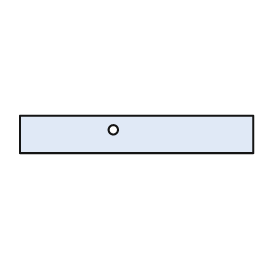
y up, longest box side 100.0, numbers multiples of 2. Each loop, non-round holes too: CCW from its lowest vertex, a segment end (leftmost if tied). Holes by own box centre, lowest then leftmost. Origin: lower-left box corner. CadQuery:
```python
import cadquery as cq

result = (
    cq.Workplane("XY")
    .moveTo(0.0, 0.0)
    .lineTo(100.0, 0.0)
    .lineTo(100.0, 16.0)
    .lineTo(0.0, 16.0)
    .close()
    .moveTo(40.0, 10.0)
    .circle(2.0)
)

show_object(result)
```